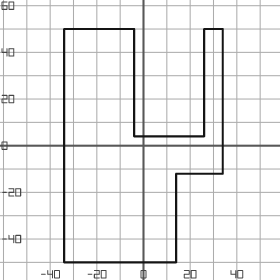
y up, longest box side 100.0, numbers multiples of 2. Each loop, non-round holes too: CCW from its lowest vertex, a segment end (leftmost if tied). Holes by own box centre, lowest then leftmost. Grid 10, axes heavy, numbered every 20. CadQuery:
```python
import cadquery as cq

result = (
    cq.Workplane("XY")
    .moveTo(-34.0, -50.0)
    .lineTo(14.0, -50.0)
    .lineTo(14.0, -12.0)
    .lineTo(34.0, -12.0)
    .lineTo(34.0, 50.0)
    .lineTo(26.0, 50.0)
    .lineTo(26.0, 4.0)
    .lineTo(-4.0, 4.0)
    .lineTo(-4.0, 50.0)
    .lineTo(-34.0, 50.0)
    .close()
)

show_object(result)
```